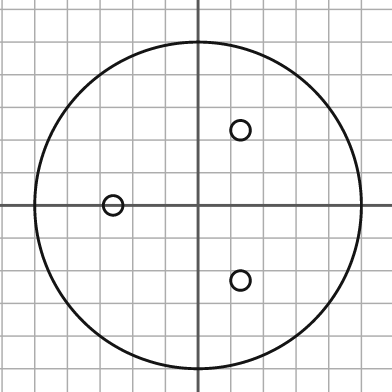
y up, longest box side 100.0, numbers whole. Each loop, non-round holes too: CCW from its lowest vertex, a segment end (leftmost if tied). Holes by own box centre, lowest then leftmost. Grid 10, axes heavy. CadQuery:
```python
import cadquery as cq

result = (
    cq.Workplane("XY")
    .moveTo(0.0, 0.0)
    .circle(50.0)
    .moveTo(13.0, -23.0)
    .circle(3.0)
    .moveTo(-26.0, 0.0)
    .circle(3.0)
    .moveTo(13.0, 23.0)
    .circle(3.0)
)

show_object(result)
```